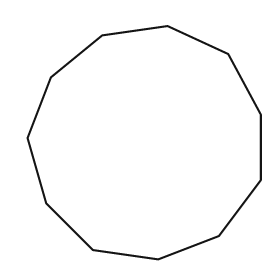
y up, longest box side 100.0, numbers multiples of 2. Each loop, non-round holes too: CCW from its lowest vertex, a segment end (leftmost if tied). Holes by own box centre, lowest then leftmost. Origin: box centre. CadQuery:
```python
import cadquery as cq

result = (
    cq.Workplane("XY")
    .moveTo(6.0, -50.0)
    .lineTo(32.0, -40.0)
    .lineTo(50.0, -16.0)
    .lineTo(50.0, 12.0)
    .lineTo(36.0, 38.0)
    .lineTo(10.0, 50.0)
    .lineTo(-18.0, 46.0)
    .lineTo(-40.0, 28.0)
    .lineTo(-50.0, 2.0)
    .lineTo(-42.0, -26.0)
    .lineTo(-22.0, -46.0)
    .close()
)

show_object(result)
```